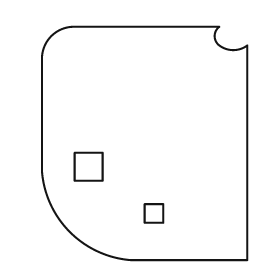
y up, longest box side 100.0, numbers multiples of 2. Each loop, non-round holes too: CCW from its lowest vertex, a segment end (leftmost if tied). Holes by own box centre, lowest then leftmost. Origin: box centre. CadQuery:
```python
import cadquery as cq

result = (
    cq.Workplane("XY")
    .moveTo(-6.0, -50.0)
    .lineTo(44.0, -50.0)
    .lineTo(44.0, 42.0)
    .threePointArc((38.0, 40.0), (32.0, 42.0))
    .threePointArc((30.0, 46.0), (32.0, 50.0))
    .lineTo(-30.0, 50.0)
    .threePointArc((-40.0, 46.0), (-44.0, 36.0))
    .lineTo(-44.0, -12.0)
    .threePointArc((-32.0, -38.0), (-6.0, -50.0))
    .close()
    .moveTo(0.0, -34.0)
    .lineTo(8.0, -34.0)
    .lineTo(8.0, -26.0)
    .lineTo(0.0, -26.0)
    .close()
    .moveTo(-30.0, -16.0)
    .lineTo(-18.0, -16.0)
    .lineTo(-18.0, -4.0)
    .lineTo(-30.0, -4.0)
    .close()
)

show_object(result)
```